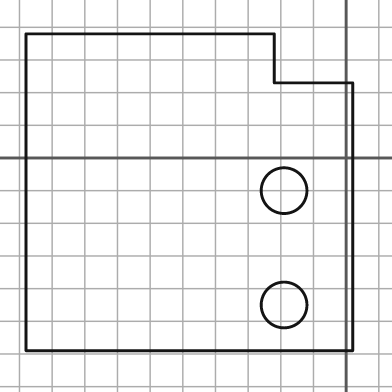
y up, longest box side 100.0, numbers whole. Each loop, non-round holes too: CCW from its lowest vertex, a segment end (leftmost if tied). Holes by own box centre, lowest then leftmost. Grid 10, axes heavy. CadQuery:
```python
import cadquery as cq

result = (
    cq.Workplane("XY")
    .moveTo(-98.0, -59.0)
    .lineTo(2.0, -59.0)
    .lineTo(2.0, 23.0)
    .lineTo(-22.0, 23.0)
    .lineTo(-22.0, 38.0)
    .lineTo(-98.0, 38.0)
    .close()
    .moveTo(-19.0, -45.0)
    .circle(7.0)
    .moveTo(-19.0, -10.0)
    .circle(7.0)
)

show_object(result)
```